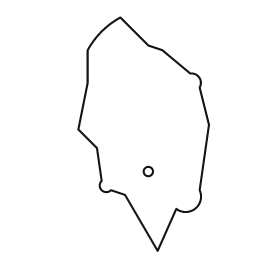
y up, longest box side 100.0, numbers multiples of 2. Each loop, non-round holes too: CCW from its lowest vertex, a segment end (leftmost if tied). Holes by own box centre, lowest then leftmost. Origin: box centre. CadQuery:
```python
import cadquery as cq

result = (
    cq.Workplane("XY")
    .moveTo(6.0, -50.0)
    .lineTo(14.0, -32.0)
    .threePointArc((22.0, -32.0), (24.0, -24.0))
    .lineTo(28.0, 4.0)
    .lineTo(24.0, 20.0)
    .threePointArc((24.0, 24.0), (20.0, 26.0))
    .lineTo(8.0, 36.0)
    .lineTo(2.0, 38.0)
    .lineTo(-10.0, 50.0)
    .threePointArc((-18.0, 44.0), (-24.0, 36.0))
    .lineTo(-24.0, 22.0)
    .lineTo(-28.0, 2.0)
    .lineTo(-20.0, -6.0)
    .lineTo(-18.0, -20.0)
    .threePointArc((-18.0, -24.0), (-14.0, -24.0))
    .lineTo(-8.0, -26.0)
    .close()
    .moveTo(2.0, -16.0)
    .circle(2.0)
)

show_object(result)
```